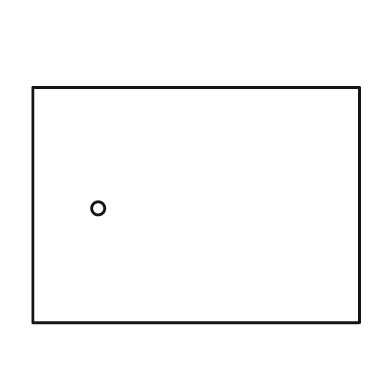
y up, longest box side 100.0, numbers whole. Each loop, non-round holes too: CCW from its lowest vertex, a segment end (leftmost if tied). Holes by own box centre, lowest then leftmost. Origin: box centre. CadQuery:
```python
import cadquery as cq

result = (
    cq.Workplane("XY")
    .moveTo(-50.0, -36.0)
    .lineTo(50.0, -36.0)
    .lineTo(50.0, 36.0)
    .lineTo(-50.0, 36.0)
    .close()
    .moveTo(-30.0, -1.0)
    .circle(2.0)
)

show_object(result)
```